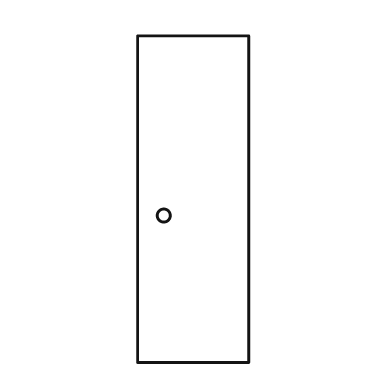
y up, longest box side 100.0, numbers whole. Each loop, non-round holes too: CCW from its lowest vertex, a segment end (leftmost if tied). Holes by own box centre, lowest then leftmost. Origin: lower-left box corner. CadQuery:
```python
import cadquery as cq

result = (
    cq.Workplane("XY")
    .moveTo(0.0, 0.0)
    .lineTo(34.0, 0.0)
    .lineTo(34.0, 100.0)
    .lineTo(0.0, 100.0)
    .close()
    .moveTo(8.0, 45.0)
    .circle(2.0)
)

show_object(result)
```